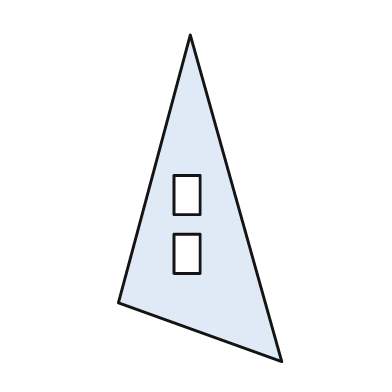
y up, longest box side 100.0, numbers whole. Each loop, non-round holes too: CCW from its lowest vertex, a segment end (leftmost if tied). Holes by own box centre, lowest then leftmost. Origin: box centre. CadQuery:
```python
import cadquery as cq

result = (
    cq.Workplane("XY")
    .moveTo(25.0, -50.0)
    .lineTo(-3.0, 50.0)
    .lineTo(-25.0, -32.0)
    .close()
    .moveTo(-8.0, -23.0)
    .lineTo(0.0, -23.0)
    .lineTo(0.0, -11.0)
    .lineTo(-8.0, -11.0)
    .close()
    .moveTo(-8.0, -5.0)
    .lineTo(0.0, -5.0)
    .lineTo(0.0, 7.0)
    .lineTo(-8.0, 7.0)
    .close()
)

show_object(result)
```